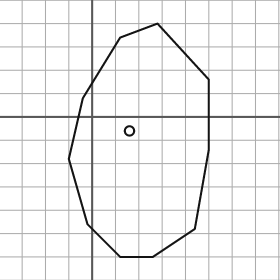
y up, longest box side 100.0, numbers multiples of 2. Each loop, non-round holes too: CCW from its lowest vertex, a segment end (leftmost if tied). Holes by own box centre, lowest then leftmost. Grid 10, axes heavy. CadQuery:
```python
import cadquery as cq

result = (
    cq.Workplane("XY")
    .moveTo(12.0, -60.0)
    .lineTo(26.0, -60.0)
    .lineTo(44.0, -48.0)
    .lineTo(50.0, -14.0)
    .lineTo(50.0, 16.0)
    .lineTo(28.0, 40.0)
    .lineTo(12.0, 34.0)
    .lineTo(-4.0, 8.0)
    .lineTo(-10.0, -18.0)
    .lineTo(-2.0, -46.0)
    .close()
    .moveTo(16.0, -6.0)
    .circle(2.0)
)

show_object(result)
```